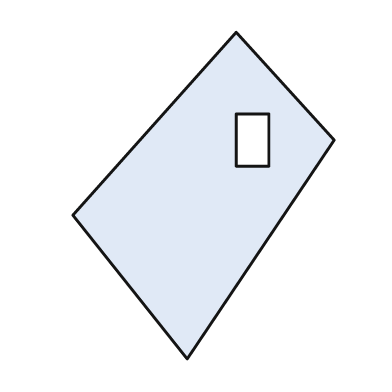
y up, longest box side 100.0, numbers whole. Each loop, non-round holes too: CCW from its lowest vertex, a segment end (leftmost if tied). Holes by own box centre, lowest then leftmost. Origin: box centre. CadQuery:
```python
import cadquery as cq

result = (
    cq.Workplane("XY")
    .moveTo(-5.0, -50.0)
    .lineTo(40.0, 17.0)
    .lineTo(10.0, 50.0)
    .lineTo(-40.0, -6.0)
    .close()
    .moveTo(10.0, 9.0)
    .lineTo(20.0, 9.0)
    .lineTo(20.0, 25.0)
    .lineTo(10.0, 25.0)
    .close()
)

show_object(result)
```